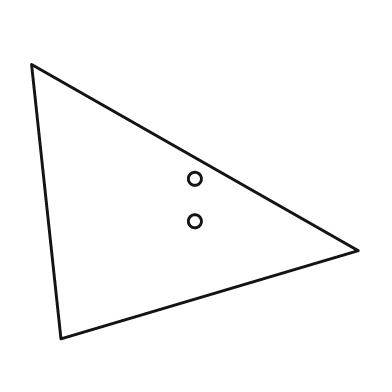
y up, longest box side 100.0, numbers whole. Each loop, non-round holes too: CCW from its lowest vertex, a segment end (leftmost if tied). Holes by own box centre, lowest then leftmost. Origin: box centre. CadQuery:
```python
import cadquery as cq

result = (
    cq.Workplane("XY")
    .moveTo(-41.0, -42.0)
    .lineTo(50.0, -15.0)
    .lineTo(-50.0, 42.0)
    .close()
    .moveTo(0.0, -6.0)
    .circle(2.0)
    .moveTo(0.0, 7.0)
    .circle(2.0)
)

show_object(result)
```